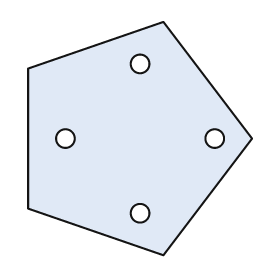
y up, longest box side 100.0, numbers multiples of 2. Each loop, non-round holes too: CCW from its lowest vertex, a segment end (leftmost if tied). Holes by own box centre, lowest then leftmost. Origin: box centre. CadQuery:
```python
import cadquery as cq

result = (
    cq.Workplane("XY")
    .moveTo(10.0, -50.0)
    .lineTo(48.0, 0.0)
    .lineTo(10.0, 50.0)
    .lineTo(-48.0, 30.0)
    .lineTo(-48.0, -30.0)
    .close()
    .moveTo(0.0, -32.0)
    .circle(4.0)
    .moveTo(-32.0, 0.0)
    .circle(4.0)
    .moveTo(32.0, 0.0)
    .circle(4.0)
    .moveTo(0.0, 32.0)
    .circle(4.0)
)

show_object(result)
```